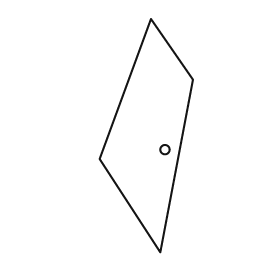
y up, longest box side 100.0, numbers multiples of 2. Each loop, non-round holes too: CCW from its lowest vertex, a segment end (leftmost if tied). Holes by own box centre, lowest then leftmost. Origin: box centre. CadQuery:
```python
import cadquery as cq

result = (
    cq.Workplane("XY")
    .moveTo(6.0, -50.0)
    .lineTo(20.0, 24.0)
    .lineTo(2.0, 50.0)
    .lineTo(-20.0, -10.0)
    .close()
    .moveTo(8.0, -6.0)
    .circle(2.0)
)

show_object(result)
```